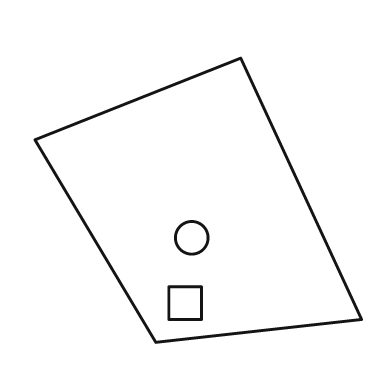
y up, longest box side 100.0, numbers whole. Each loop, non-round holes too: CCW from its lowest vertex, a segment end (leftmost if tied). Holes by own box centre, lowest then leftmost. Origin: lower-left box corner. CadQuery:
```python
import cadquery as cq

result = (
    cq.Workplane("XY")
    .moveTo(37.0, 0.0)
    .lineTo(100.0, 7.0)
    .lineTo(63.0, 87.0)
    .lineTo(0.0, 62.0)
    .close()
    .moveTo(41.0, 7.0)
    .lineTo(51.0, 7.0)
    .lineTo(51.0, 17.0)
    .lineTo(41.0, 17.0)
    .close()
    .moveTo(48.0, 32.0)
    .circle(5.0)
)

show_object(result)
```